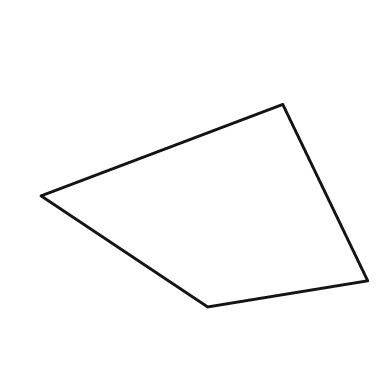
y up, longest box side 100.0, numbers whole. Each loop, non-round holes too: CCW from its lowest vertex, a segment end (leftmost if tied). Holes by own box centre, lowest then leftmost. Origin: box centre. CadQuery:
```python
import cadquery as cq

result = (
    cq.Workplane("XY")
    .moveTo(1.0, -31.0)
    .lineTo(50.0, -23.0)
    .lineTo(24.0, 31.0)
    .lineTo(-50.0, 3.0)
    .close()
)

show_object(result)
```